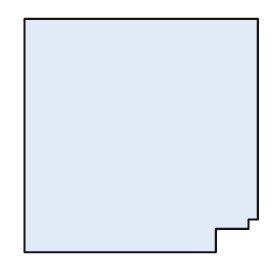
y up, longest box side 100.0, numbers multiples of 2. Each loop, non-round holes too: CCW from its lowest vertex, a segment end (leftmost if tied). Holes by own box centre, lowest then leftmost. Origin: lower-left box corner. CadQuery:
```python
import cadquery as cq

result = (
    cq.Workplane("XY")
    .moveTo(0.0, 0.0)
    .lineTo(82.0, 0.0)
    .lineTo(82.0, 10.0)
    .lineTo(96.0, 10.0)
    .lineTo(96.0, 14.0)
    .lineTo(100.0, 14.0)
    .lineTo(100.0, 100.0)
    .lineTo(0.0, 100.0)
    .close()
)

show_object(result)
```